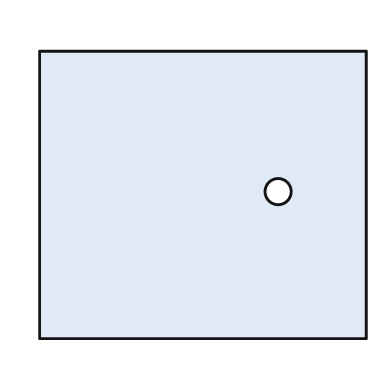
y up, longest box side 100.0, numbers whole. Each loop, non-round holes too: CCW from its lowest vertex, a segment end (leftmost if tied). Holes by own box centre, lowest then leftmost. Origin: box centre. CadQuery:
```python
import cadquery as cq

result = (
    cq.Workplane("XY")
    .moveTo(-50.0, -44.0)
    .lineTo(50.0, -44.0)
    .lineTo(50.0, 44.0)
    .lineTo(-50.0, 44.0)
    .close()
    .moveTo(23.0, 1.0)
    .circle(4.0)
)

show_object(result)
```